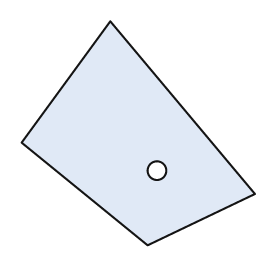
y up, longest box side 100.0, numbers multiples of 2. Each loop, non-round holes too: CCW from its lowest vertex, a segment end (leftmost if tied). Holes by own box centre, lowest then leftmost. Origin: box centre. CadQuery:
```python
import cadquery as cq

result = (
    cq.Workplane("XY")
    .moveTo(4.0, -48.0)
    .lineTo(50.0, -26.0)
    .lineTo(-12.0, 48.0)
    .lineTo(-50.0, -4.0)
    .close()
    .moveTo(8.0, -16.0)
    .circle(4.0)
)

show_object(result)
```